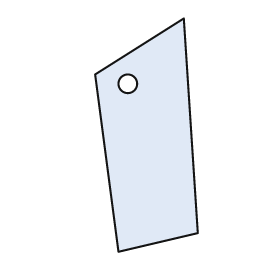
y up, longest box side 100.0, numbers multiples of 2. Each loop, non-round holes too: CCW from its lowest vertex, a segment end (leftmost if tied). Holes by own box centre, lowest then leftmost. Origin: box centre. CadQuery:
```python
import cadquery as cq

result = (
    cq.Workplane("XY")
    .moveTo(-12.0, -50.0)
    .lineTo(22.0, -42.0)
    .lineTo(16.0, 50.0)
    .lineTo(-22.0, 26.0)
    .close()
    .moveTo(-8.0, 22.0)
    .circle(4.0)
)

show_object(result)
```